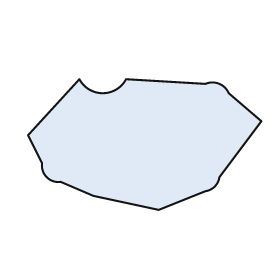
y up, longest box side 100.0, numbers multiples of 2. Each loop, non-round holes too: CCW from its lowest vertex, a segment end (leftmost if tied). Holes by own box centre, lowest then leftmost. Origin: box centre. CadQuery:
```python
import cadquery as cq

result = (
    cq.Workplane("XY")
    .moveTo(6.0, -28.0)
    .lineTo(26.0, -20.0)
    .threePointArc((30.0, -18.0), (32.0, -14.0))
    .lineTo(50.0, 10.0)
    .lineTo(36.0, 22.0)
    .threePointArc((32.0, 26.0), (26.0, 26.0))
    .lineTo(-8.0, 28.0)
    .threePointArc((-18.0, 22.0), (-28.0, 28.0))
    .lineTo(-50.0, 4.0)
    .lineTo(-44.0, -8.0)
    .threePointArc((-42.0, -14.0), (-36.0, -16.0))
    .lineTo(-22.0, -22.0)
    .close()
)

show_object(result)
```